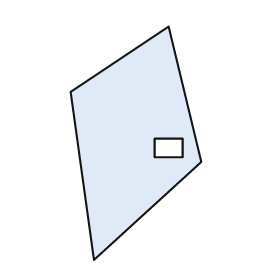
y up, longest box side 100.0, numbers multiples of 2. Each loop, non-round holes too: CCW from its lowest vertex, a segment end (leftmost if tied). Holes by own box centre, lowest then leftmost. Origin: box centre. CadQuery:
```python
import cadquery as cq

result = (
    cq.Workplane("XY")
    .moveTo(-18.0, -50.0)
    .lineTo(28.0, -8.0)
    .lineTo(14.0, 50.0)
    .lineTo(-28.0, 22.0)
    .close()
    .moveTo(8.0, -6.0)
    .lineTo(20.0, -6.0)
    .lineTo(20.0, 2.0)
    .lineTo(8.0, 2.0)
    .close()
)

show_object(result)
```